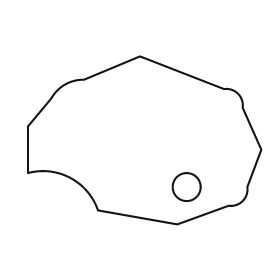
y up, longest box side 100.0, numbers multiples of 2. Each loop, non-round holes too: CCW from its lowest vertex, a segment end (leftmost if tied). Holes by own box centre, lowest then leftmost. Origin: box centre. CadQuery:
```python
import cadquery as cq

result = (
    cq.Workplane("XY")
    .moveTo(14.0, -36.0)
    .lineTo(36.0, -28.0)
    .threePointArc((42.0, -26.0), (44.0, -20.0))
    .lineTo(50.0, -4.0)
    .lineTo(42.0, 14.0)
    .threePointArc((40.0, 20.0), (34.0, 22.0))
    .lineTo(-2.0, 36.0)
    .lineTo(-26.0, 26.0)
    .threePointArc((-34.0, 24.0), (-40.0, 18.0))
    .lineTo(-50.0, 6.0)
    .lineTo(-50.0, -14.0)
    .threePointArc((-32.0, -16.0), (-20.0, -30.0))
    .close()
    .moveTo(18.0, -20.0)
    .circle(6.0)
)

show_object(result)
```